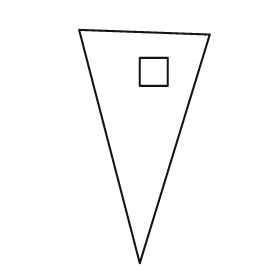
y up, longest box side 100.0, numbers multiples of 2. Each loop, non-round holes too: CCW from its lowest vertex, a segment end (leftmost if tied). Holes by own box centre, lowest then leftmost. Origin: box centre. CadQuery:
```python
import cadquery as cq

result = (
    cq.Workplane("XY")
    .moveTo(-2.0, -50.0)
    .lineTo(28.0, 48.0)
    .lineTo(-28.0, 50.0)
    .close()
    .moveTo(-2.0, 26.0)
    .lineTo(10.0, 26.0)
    .lineTo(10.0, 38.0)
    .lineTo(-2.0, 38.0)
    .close()
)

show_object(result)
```